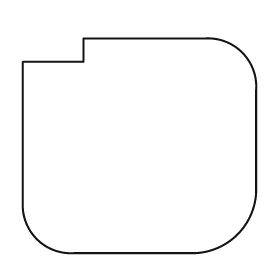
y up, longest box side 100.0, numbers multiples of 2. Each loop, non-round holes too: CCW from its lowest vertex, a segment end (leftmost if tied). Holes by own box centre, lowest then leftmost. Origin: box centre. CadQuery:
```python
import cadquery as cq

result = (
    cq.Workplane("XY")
    .moveTo(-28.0, -46.0)
    .lineTo(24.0, -46.0)
    .threePointArc((42.0, -38.0), (50.0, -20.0))
    .lineTo(50.0, 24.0)
    .threePointArc((44.0, 40.0), (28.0, 46.0))
    .lineTo(-24.0, 46.0)
    .lineTo(-24.0, 36.0)
    .lineTo(-50.0, 36.0)
    .lineTo(-50.0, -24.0)
    .threePointArc((-44.0, -40.0), (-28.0, -46.0))
    .close()
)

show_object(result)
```